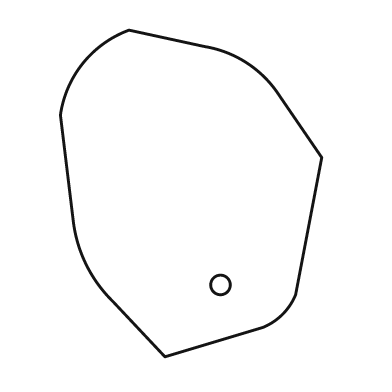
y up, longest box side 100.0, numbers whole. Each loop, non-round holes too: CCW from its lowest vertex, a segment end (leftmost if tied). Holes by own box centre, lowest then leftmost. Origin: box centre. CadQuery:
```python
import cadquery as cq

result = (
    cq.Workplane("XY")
    .moveTo(-8.0, -50.0)
    .lineTo(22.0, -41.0)
    .threePointArc((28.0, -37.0), (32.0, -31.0))
    .lineTo(40.0, 11.0)
    .lineTo(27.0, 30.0)
    .threePointArc((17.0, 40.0), (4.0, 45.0))
    .lineTo(-19.0, 50.0)
    .threePointArc((-33.0, 40.0), (-40.0, 24.0))
    .lineTo(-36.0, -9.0)
    .threePointArc((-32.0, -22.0), (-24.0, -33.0))
    .close()
    .moveTo(9.0, -28.0)
    .circle(3.0)
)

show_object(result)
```